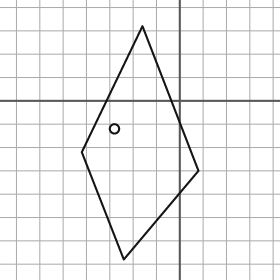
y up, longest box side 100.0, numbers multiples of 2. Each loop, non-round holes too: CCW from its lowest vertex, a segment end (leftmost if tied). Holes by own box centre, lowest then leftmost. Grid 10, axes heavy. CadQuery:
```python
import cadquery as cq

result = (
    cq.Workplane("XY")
    .moveTo(-24.0, -68.0)
    .lineTo(8.0, -30.0)
    .lineTo(-16.0, 32.0)
    .lineTo(-42.0, -22.0)
    .close()
    .moveTo(-28.0, -12.0)
    .circle(2.0)
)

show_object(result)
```